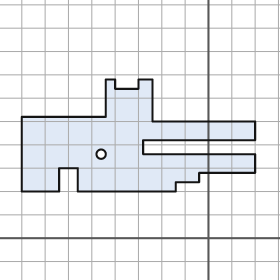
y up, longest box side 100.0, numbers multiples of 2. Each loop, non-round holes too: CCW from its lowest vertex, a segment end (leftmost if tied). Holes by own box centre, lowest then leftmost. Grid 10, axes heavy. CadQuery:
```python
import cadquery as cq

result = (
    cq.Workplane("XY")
    .moveTo(-80.0, 20.0)
    .lineTo(-64.0, 20.0)
    .lineTo(-64.0, 30.0)
    .lineTo(-56.0, 30.0)
    .lineTo(-56.0, 20.0)
    .lineTo(-14.0, 20.0)
    .lineTo(-14.0, 24.0)
    .lineTo(-4.0, 24.0)
    .lineTo(-4.0, 28.0)
    .lineTo(20.0, 28.0)
    .lineTo(20.0, 36.0)
    .lineTo(-28.0, 36.0)
    .lineTo(-28.0, 42.0)
    .lineTo(20.0, 42.0)
    .lineTo(20.0, 50.0)
    .lineTo(-24.0, 50.0)
    .lineTo(-24.0, 68.0)
    .lineTo(-30.0, 68.0)
    .lineTo(-30.0, 64.0)
    .lineTo(-40.0, 64.0)
    .lineTo(-40.0, 68.0)
    .lineTo(-44.0, 68.0)
    .lineTo(-44.0, 52.0)
    .lineTo(-80.0, 52.0)
    .close()
    .moveTo(-46.0, 36.0)
    .circle(2.0)
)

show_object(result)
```